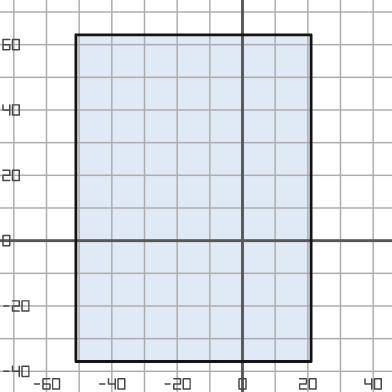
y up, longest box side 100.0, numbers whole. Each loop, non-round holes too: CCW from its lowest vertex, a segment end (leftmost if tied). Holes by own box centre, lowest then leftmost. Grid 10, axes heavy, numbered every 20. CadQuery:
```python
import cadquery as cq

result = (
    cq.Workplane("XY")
    .moveTo(-51.0, -37.0)
    .lineTo(21.0, -37.0)
    .lineTo(21.0, 63.0)
    .lineTo(-51.0, 63.0)
    .close()
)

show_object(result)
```